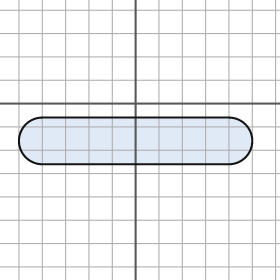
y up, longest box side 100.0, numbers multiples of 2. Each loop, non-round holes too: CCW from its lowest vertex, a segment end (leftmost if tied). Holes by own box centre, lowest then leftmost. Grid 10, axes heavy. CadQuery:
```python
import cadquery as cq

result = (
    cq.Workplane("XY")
    .moveTo(-40.0, -26.0)
    .lineTo(40.0, -26.0)
    .threePointArc((50.0, -16.0), (40.0, -6.0))
    .lineTo(-40.0, -6.0)
    .threePointArc((-50.0, -16.0), (-40.0, -26.0))
    .close()
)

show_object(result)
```